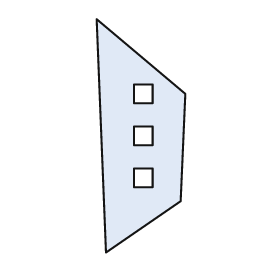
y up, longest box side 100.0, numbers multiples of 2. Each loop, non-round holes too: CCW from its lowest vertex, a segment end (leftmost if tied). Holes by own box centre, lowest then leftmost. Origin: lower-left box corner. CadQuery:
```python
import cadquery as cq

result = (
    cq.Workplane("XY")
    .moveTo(4.0, 0.0)
    .lineTo(36.0, 22.0)
    .lineTo(38.0, 68.0)
    .lineTo(0.0, 100.0)
    .close()
    .moveTo(16.0, 28.0)
    .lineTo(24.0, 28.0)
    .lineTo(24.0, 36.0)
    .lineTo(16.0, 36.0)
    .close()
    .moveTo(16.0, 46.0)
    .lineTo(24.0, 46.0)
    .lineTo(24.0, 54.0)
    .lineTo(16.0, 54.0)
    .close()
    .moveTo(16.0, 64.0)
    .lineTo(24.0, 64.0)
    .lineTo(24.0, 72.0)
    .lineTo(16.0, 72.0)
    .close()
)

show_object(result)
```